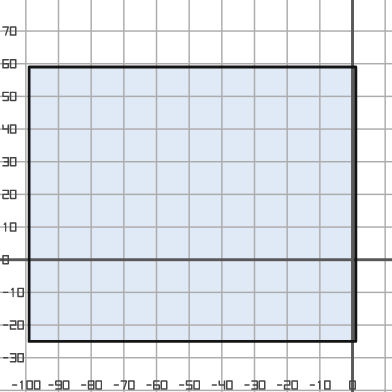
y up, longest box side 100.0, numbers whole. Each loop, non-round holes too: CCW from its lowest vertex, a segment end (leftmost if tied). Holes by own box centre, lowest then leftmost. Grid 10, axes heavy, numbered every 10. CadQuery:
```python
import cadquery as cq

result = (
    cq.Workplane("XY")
    .moveTo(-99.0, -25.0)
    .lineTo(1.0, -25.0)
    .lineTo(1.0, 59.0)
    .lineTo(-99.0, 59.0)
    .close()
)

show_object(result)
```